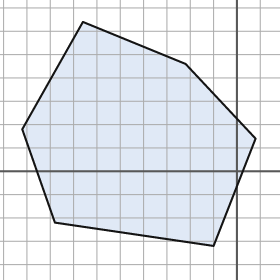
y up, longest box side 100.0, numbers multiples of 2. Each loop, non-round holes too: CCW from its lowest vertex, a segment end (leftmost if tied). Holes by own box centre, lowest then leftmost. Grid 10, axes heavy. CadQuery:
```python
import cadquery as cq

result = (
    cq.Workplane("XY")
    .moveTo(-10.0, -32.0)
    .lineTo(8.0, 14.0)
    .lineTo(-22.0, 46.0)
    .lineTo(-66.0, 64.0)
    .lineTo(-92.0, 18.0)
    .lineTo(-78.0, -22.0)
    .close()
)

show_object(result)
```